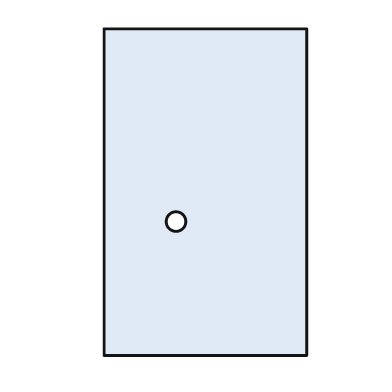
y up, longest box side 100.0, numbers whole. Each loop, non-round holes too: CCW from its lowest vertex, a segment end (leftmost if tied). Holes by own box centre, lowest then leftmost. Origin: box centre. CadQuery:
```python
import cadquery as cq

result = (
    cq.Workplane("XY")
    .moveTo(-31.0, -50.0)
    .lineTo(31.0, -50.0)
    .lineTo(31.0, 50.0)
    .lineTo(-31.0, 50.0)
    .close()
    .moveTo(-9.0, -9.0)
    .circle(3.0)
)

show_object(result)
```